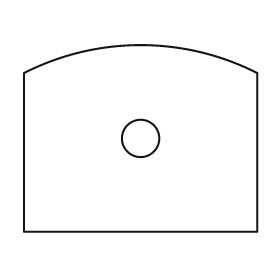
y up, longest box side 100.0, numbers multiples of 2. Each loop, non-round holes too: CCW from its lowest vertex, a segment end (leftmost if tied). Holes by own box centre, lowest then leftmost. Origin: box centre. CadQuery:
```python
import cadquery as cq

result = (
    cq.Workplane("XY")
    .moveTo(-50.0, -40.0)
    .lineTo(50.0, -40.0)
    .lineTo(50.0, 28.0)
    .threePointArc((0.0, 40.0), (-50.0, 28.0))
    .close()
    .moveTo(0.0, 0.0)
    .circle(8.0)
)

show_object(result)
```